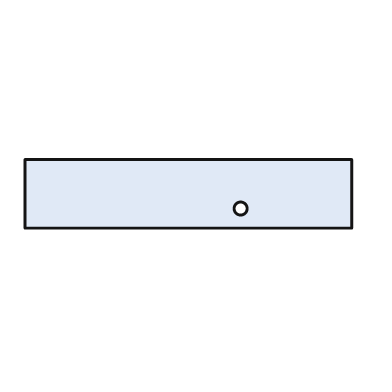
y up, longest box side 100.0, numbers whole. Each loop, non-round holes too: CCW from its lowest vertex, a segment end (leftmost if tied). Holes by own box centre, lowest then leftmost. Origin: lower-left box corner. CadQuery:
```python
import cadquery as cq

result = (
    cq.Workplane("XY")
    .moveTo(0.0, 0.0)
    .lineTo(100.0, 0.0)
    .lineTo(100.0, 21.0)
    .lineTo(0.0, 21.0)
    .close()
    .moveTo(66.0, 6.0)
    .circle(2.0)
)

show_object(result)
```